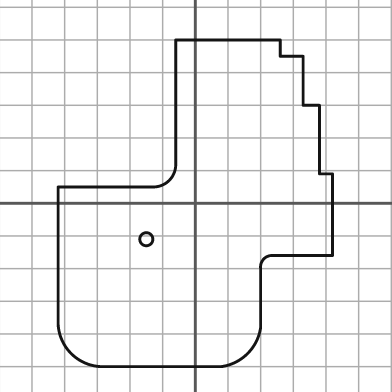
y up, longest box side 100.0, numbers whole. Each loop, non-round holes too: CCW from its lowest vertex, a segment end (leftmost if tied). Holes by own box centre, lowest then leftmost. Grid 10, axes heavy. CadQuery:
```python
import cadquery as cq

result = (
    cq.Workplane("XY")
    .moveTo(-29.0, -50.0)
    .lineTo(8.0, -50.0)
    .threePointArc((16.0, -46.0), (20.0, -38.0))
    .lineTo(20.0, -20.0)
    .threePointArc((21.0, -17.0), (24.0, -16.0))
    .lineTo(42.0, -16.0)
    .lineTo(42.0, 9.0)
    .lineTo(38.0, 9.0)
    .lineTo(38.0, 30.0)
    .lineTo(33.0, 30.0)
    .lineTo(33.0, 45.0)
    .lineTo(26.0, 45.0)
    .lineTo(26.0, 50.0)
    .lineTo(-6.0, 50.0)
    .lineTo(-6.0, 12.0)
    .threePointArc((-8.0, 7.0), (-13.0, 5.0))
    .lineTo(-42.0, 5.0)
    .lineTo(-42.0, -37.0)
    .threePointArc((-38.0, -46.0), (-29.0, -50.0))
    .close()
    .moveTo(-15.0, -11.0)
    .circle(2.0)
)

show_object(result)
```